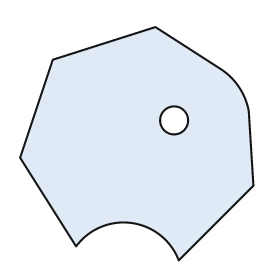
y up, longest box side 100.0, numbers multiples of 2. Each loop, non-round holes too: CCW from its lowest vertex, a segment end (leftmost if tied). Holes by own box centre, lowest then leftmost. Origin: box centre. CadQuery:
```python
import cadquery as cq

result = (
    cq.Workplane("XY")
    .moveTo(18.0, -50.0)
    .lineTo(50.0, -18.0)
    .lineTo(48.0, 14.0)
    .threePointArc((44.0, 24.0), (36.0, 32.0))
    .lineTo(8.0, 50.0)
    .lineTo(-36.0, 36.0)
    .lineTo(-50.0, -6.0)
    .lineTo(-26.0, -44.0)
    .threePointArc((-2.0, -34.0), (18.0, -50.0))
    .close()
    .moveTo(16.0, 10.0)
    .circle(6.0)
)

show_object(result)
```